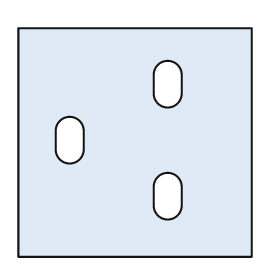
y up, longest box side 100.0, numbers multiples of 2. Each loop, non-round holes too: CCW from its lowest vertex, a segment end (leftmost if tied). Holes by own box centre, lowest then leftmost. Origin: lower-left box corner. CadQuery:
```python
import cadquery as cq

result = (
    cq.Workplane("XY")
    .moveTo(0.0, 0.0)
    .lineTo(100.0, 0.0)
    .lineTo(100.0, 98.0)
    .lineTo(0.0, 98.0)
    .close()
    .moveTo(58.0, 22.0)
    .threePointArc((64.0, 16.0), (70.0, 22.0))
    .lineTo(70.0, 30.0)
    .threePointArc((64.0, 36.0), (58.0, 30.0))
    .close()
    .moveTo(16.0, 46.0)
    .threePointArc((22.0, 40.0), (28.0, 46.0))
    .lineTo(28.0, 54.0)
    .threePointArc((22.0, 60.0), (16.0, 54.0))
    .close()
    .moveTo(58.0, 70.0)
    .threePointArc((64.0, 64.0), (70.0, 70.0))
    .lineTo(70.0, 78.0)
    .threePointArc((64.0, 84.0), (58.0, 78.0))
    .close()
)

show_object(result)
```